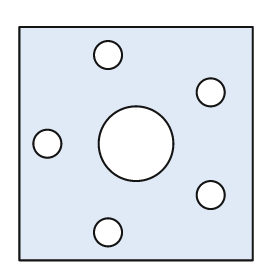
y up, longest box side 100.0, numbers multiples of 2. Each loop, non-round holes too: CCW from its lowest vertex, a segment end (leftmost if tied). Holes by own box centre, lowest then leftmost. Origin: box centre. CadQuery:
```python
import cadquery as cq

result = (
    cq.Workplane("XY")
    .moveTo(-50.0, -50.0)
    .lineTo(50.0, -50.0)
    .lineTo(50.0, 50.0)
    .lineTo(-50.0, 50.0)
    .close()
    .moveTo(-12.0, -38.0)
    .circle(6.0)
    .moveTo(32.0, -22.0)
    .circle(6.0)
    .moveTo(-38.0, 0.0)
    .circle(6.0)
    .moveTo(0.0, 0.0)
    .circle(16.0)
    .moveTo(32.0, 22.0)
    .circle(6.0)
    .moveTo(-12.0, 38.0)
    .circle(6.0)
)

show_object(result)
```